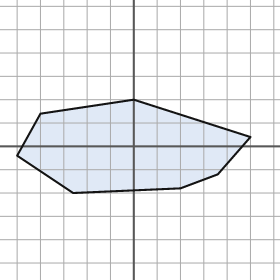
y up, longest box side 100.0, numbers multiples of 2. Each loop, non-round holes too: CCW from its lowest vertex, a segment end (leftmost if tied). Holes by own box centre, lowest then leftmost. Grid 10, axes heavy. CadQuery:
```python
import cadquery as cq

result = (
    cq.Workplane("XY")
    .moveTo(-26.0, -20.0)
    .lineTo(20.0, -18.0)
    .lineTo(36.0, -12.0)
    .lineTo(50.0, 4.0)
    .lineTo(0.0, 20.0)
    .lineTo(-40.0, 14.0)
    .lineTo(-50.0, -4.0)
    .close()
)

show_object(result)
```